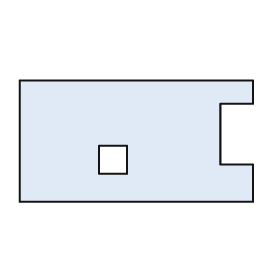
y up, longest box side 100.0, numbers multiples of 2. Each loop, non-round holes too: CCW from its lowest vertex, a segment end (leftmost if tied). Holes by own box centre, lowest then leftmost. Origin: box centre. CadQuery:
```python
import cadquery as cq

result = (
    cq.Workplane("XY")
    .moveTo(-50.0, -26.0)
    .lineTo(50.0, -26.0)
    .lineTo(50.0, -10.0)
    .lineTo(36.0, -10.0)
    .lineTo(36.0, 16.0)
    .lineTo(50.0, 16.0)
    .lineTo(50.0, 26.0)
    .lineTo(-50.0, 26.0)
    .close()
    .moveTo(-16.0, -14.0)
    .lineTo(-4.0, -14.0)
    .lineTo(-4.0, -2.0)
    .lineTo(-16.0, -2.0)
    .close()
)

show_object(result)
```